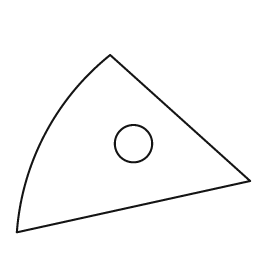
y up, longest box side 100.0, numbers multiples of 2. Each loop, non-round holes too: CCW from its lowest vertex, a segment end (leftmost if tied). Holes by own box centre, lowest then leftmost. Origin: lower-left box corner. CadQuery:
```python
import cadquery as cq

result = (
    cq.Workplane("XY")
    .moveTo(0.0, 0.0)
    .lineTo(100.0, 22.0)
    .lineTo(40.0, 76.0)
    .threePointArc((12.0, 42.0), (0.0, 0.0))
    .close()
    .moveTo(50.0, 38.0)
    .circle(8.0)
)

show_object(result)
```